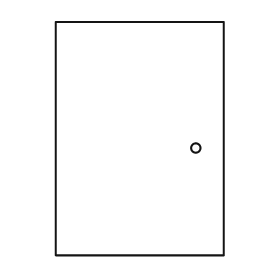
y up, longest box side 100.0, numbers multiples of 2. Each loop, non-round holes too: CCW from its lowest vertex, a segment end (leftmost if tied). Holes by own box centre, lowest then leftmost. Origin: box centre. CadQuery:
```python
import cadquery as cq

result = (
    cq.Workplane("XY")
    .moveTo(-36.0, -50.0)
    .lineTo(36.0, -50.0)
    .lineTo(36.0, 50.0)
    .lineTo(-36.0, 50.0)
    .close()
    .moveTo(24.0, -4.0)
    .circle(2.0)
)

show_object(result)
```